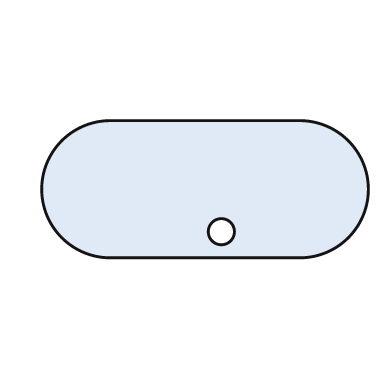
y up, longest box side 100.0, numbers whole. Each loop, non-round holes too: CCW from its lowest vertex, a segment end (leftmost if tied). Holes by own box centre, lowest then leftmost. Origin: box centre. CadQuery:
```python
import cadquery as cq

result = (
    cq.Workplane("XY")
    .moveTo(-29.0, -21.0)
    .lineTo(29.0, -21.0)
    .threePointArc((50.0, 0.0), (29.0, 21.0))
    .lineTo(-29.0, 21.0)
    .threePointArc((-50.0, 0.0), (-29.0, -21.0))
    .close()
    .moveTo(5.0, -13.0)
    .circle(4.0)
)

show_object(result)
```